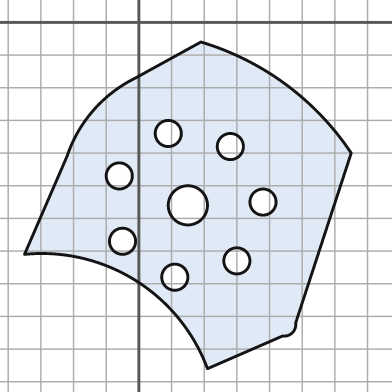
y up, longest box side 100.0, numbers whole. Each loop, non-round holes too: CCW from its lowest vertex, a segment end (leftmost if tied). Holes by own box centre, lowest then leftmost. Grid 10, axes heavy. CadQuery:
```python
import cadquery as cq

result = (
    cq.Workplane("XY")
    .moveTo(21.0, -106.0)
    .lineTo(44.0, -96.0)
    .threePointArc((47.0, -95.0), (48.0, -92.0))
    .lineTo(65.0, -40.0)
    .threePointArc((45.0, -19.0), (19.0, -6.0))
    .lineTo(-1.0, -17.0)
    .threePointArc((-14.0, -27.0), (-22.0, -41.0))
    .lineTo(-35.0, -71.0)
    .threePointArc((-1.0, -79.0), (21.0, -106.0))
    .close()
    .moveTo(11.0, -78.0)
    .circle(4.0)
    .moveTo(30.0, -73.0)
    .circle(4.0)
    .moveTo(-5.0, -67.0)
    .circle(4.0)
    .moveTo(15.0, -56.0)
    .circle(6.0)
    .moveTo(38.0, -55.0)
    .circle(4.0)
    .moveTo(-6.0, -47.0)
    .circle(4.0)
    .moveTo(28.0, -38.0)
    .circle(4.0)
    .moveTo(9.0, -34.0)
    .circle(4.0)
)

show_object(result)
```